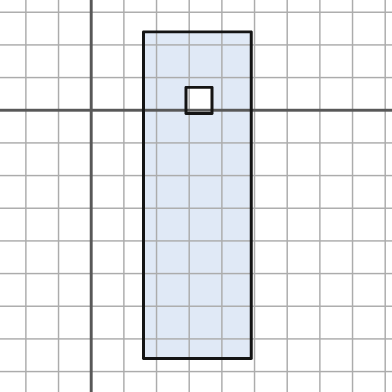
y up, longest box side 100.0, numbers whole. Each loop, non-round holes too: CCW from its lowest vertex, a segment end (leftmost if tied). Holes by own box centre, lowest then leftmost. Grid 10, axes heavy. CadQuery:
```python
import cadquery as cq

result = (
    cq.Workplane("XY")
    .moveTo(16.0, -76.0)
    .lineTo(49.0, -76.0)
    .lineTo(49.0, 24.0)
    .lineTo(16.0, 24.0)
    .close()
    .moveTo(29.0, -1.0)
    .lineTo(37.0, -1.0)
    .lineTo(37.0, 7.0)
    .lineTo(29.0, 7.0)
    .close()
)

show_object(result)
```